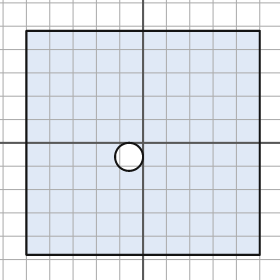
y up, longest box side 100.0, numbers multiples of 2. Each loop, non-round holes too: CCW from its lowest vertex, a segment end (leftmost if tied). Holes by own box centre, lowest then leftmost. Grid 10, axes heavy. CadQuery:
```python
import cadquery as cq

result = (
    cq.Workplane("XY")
    .moveTo(-50.0, -48.0)
    .lineTo(50.0, -48.0)
    .lineTo(50.0, 48.0)
    .lineTo(-50.0, 48.0)
    .close()
    .moveTo(-6.0, -6.0)
    .circle(6.0)
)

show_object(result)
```